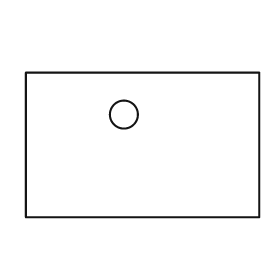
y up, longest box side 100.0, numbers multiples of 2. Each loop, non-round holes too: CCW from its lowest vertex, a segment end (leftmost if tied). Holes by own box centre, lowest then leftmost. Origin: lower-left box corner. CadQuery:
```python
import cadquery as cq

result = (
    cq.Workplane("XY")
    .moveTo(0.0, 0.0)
    .lineTo(100.0, 0.0)
    .lineTo(100.0, 62.0)
    .lineTo(0.0, 62.0)
    .close()
    .moveTo(42.0, 44.0)
    .circle(6.0)
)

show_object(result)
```